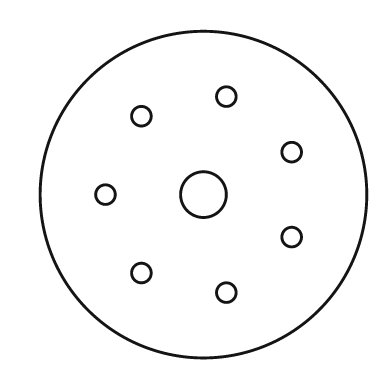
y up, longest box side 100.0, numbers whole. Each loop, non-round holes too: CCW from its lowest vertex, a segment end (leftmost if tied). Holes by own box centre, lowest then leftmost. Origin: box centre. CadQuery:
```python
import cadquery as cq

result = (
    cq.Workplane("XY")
    .moveTo(0.0, 0.0)
    .circle(50.0)
    .moveTo(7.0, -30.0)
    .circle(3.0)
    .moveTo(-19.0, -24.0)
    .circle(3.0)
    .moveTo(27.0, -13.0)
    .circle(3.0)
    .moveTo(-30.0, 0.0)
    .circle(3.0)
    .moveTo(0.0, 0.0)
    .circle(7.0)
    .moveTo(27.0, 13.0)
    .circle(3.0)
    .moveTo(-19.0, 24.0)
    .circle(3.0)
    .moveTo(7.0, 30.0)
    .circle(3.0)
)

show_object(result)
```